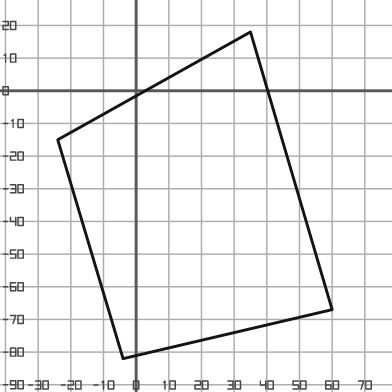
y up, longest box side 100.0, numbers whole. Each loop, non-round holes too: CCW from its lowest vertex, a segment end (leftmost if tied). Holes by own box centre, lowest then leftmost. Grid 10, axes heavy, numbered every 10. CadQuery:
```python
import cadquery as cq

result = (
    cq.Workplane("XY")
    .moveTo(-4.0, -82.0)
    .lineTo(60.0, -67.0)
    .lineTo(35.0, 18.0)
    .lineTo(-24.0, -15.0)
    .close()
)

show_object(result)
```